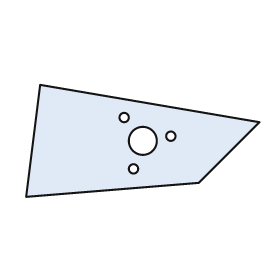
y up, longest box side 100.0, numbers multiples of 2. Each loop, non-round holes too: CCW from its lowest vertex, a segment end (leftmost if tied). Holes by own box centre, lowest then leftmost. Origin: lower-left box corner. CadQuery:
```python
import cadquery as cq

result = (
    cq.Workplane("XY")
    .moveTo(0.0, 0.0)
    .lineTo(74.0, 6.0)
    .lineTo(100.0, 32.0)
    .lineTo(6.0, 48.0)
    .close()
    .moveTo(46.0, 12.0)
    .circle(2.0)
    .moveTo(50.0, 24.0)
    .circle(6.0)
    .moveTo(62.0, 26.0)
    .circle(2.0)
    .moveTo(42.0, 34.0)
    .circle(2.0)
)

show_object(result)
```